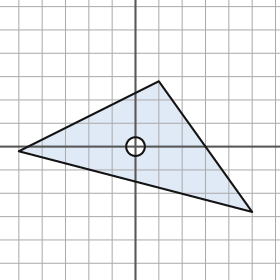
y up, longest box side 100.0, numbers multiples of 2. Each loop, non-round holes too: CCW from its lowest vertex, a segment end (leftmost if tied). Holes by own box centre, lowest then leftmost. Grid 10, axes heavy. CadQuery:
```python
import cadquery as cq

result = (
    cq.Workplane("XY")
    .moveTo(50.0, -28.0)
    .lineTo(10.0, 28.0)
    .lineTo(-50.0, -2.0)
    .close()
    .moveTo(0.0, 0.0)
    .circle(4.0)
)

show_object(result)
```